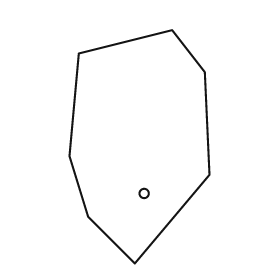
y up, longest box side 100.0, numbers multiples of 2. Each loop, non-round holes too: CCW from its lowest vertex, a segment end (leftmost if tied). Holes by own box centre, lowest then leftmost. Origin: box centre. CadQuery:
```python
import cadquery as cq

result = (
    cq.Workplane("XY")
    .moveTo(-2.0, -50.0)
    .lineTo(30.0, -12.0)
    .lineTo(28.0, 32.0)
    .lineTo(14.0, 50.0)
    .lineTo(-26.0, 40.0)
    .lineTo(-30.0, -4.0)
    .lineTo(-22.0, -30.0)
    .close()
    .moveTo(2.0, -20.0)
    .circle(2.0)
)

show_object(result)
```